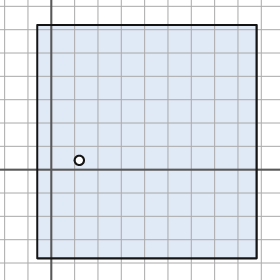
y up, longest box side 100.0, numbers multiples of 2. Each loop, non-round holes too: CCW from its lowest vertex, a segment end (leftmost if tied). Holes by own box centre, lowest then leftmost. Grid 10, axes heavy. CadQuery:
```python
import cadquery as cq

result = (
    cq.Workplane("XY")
    .moveTo(-6.0, -38.0)
    .lineTo(88.0, -38.0)
    .lineTo(88.0, 62.0)
    .lineTo(-6.0, 62.0)
    .close()
    .moveTo(12.0, 4.0)
    .circle(2.0)
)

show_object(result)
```